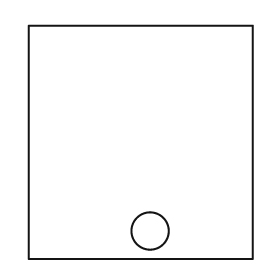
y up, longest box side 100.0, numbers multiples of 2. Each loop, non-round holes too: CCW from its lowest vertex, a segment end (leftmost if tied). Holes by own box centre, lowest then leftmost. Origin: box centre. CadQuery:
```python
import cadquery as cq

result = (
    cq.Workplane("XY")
    .moveTo(-48.0, -50.0)
    .lineTo(48.0, -50.0)
    .lineTo(48.0, 50.0)
    .lineTo(-48.0, 50.0)
    .close()
    .moveTo(4.0, -38.0)
    .circle(8.0)
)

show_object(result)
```